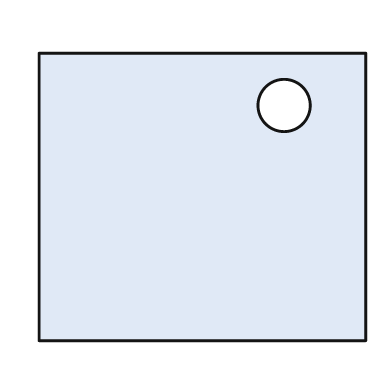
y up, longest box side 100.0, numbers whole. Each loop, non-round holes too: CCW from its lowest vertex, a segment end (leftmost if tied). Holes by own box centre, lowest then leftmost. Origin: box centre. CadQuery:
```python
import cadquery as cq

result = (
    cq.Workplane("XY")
    .moveTo(-50.0, -44.0)
    .lineTo(50.0, -44.0)
    .lineTo(50.0, 44.0)
    .lineTo(-50.0, 44.0)
    .close()
    .moveTo(25.0, 28.0)
    .circle(8.0)
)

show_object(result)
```